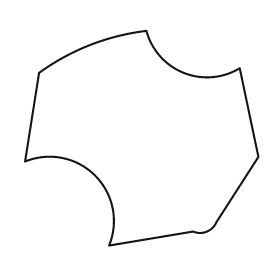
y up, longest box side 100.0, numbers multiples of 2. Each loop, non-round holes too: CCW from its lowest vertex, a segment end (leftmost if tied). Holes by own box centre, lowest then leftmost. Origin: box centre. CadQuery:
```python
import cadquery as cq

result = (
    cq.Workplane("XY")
    .moveTo(-14.0, -46.0)
    .lineTo(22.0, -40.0)
    .threePointArc((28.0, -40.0), (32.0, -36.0))
    .lineTo(50.0, -8.0)
    .lineTo(42.0, 30.0)
    .threePointArc((18.0, 28.0), (2.0, 46.0))
    .threePointArc((-22.0, 40.0), (-44.0, 28.0))
    .lineTo(-50.0, -10.0)
    .threePointArc((-20.0, -16.0), (-14.0, -46.0))
    .close()
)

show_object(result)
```